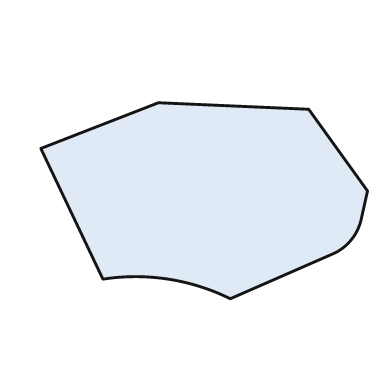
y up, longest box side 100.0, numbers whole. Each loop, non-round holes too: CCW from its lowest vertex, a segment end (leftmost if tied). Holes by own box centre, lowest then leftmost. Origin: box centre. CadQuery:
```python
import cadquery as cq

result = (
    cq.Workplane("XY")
    .moveTo(8.0, -30.0)
    .lineTo(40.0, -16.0)
    .threePointArc((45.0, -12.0), (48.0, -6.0))
    .lineTo(50.0, 3.0)
    .lineTo(32.0, 28.0)
    .lineTo(-14.0, 30.0)
    .lineTo(-50.0, 16.0)
    .lineTo(-31.0, -24.0)
    .threePointArc((-11.0, -24.0), (8.0, -30.0))
    .close()
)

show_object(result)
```